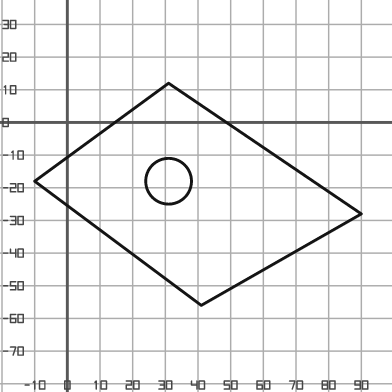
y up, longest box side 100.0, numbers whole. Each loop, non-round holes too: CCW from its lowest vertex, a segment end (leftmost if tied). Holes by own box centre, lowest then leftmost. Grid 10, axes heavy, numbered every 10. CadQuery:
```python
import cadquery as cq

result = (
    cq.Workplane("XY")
    .moveTo(41.0, -56.0)
    .lineTo(90.0, -28.0)
    .lineTo(31.0, 12.0)
    .lineTo(-10.0, -18.0)
    .close()
    .moveTo(31.0, -18.0)
    .circle(7.0)
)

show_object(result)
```